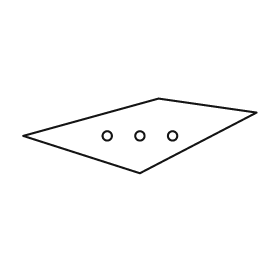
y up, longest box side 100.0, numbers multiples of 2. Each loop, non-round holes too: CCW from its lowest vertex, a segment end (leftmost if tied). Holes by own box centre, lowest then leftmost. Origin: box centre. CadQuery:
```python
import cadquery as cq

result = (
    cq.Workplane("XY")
    .moveTo(0.0, -16.0)
    .lineTo(50.0, 10.0)
    .lineTo(8.0, 16.0)
    .lineTo(-50.0, 0.0)
    .close()
    .moveTo(-14.0, 0.0)
    .circle(2.0)
    .moveTo(0.0, 0.0)
    .circle(2.0)
    .moveTo(14.0, 0.0)
    .circle(2.0)
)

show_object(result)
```